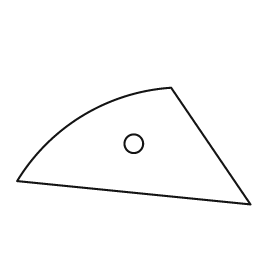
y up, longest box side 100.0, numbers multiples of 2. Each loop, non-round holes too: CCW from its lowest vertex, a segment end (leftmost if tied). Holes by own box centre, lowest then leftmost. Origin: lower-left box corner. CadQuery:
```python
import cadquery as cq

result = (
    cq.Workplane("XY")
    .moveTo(100.0, 0.0)
    .lineTo(66.0, 50.0)
    .threePointArc((28.0, 38.0), (0.0, 10.0))
    .close()
    .moveTo(50.0, 26.0)
    .circle(4.0)
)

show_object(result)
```